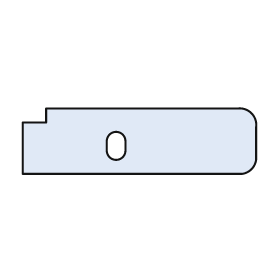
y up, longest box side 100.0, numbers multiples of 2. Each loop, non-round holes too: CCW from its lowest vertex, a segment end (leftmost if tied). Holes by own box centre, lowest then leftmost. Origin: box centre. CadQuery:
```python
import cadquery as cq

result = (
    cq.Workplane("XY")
    .moveTo(-50.0, -14.0)
    .lineTo(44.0, -14.0)
    .threePointArc((48.0, -12.0), (50.0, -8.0))
    .lineTo(50.0, 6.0)
    .threePointArc((48.0, 12.0), (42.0, 14.0))
    .lineTo(-40.0, 14.0)
    .lineTo(-40.0, 8.0)
    .lineTo(-50.0, 8.0)
    .close()
    .moveTo(-14.0, -4.0)
    .threePointArc((-10.0, -8.0), (-6.0, -4.0))
    .lineTo(-6.0, 0.0)
    .threePointArc((-10.0, 4.0), (-14.0, 0.0))
    .close()
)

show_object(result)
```